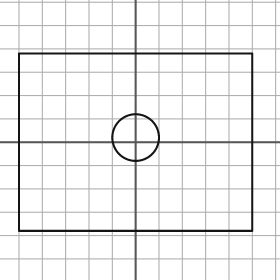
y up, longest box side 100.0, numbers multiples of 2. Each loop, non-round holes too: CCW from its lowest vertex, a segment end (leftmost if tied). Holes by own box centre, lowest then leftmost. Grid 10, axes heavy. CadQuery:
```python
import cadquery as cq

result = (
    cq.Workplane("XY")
    .moveTo(-50.0, -38.0)
    .lineTo(50.0, -38.0)
    .lineTo(50.0, 38.0)
    .lineTo(-50.0, 38.0)
    .close()
    .moveTo(0.0, 2.0)
    .circle(10.0)
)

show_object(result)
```